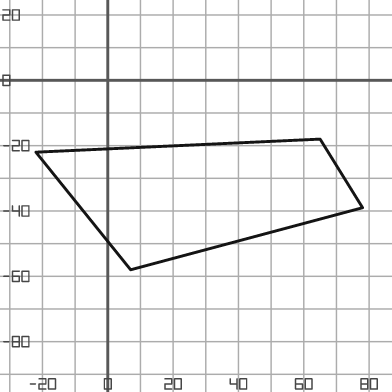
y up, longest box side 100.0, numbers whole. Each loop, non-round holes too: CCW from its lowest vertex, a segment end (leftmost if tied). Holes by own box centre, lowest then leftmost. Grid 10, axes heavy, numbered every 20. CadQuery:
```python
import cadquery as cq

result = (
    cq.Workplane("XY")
    .moveTo(7.0, -58.0)
    .lineTo(78.0, -39.0)
    .lineTo(65.0, -18.0)
    .lineTo(-22.0, -22.0)
    .close()
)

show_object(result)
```